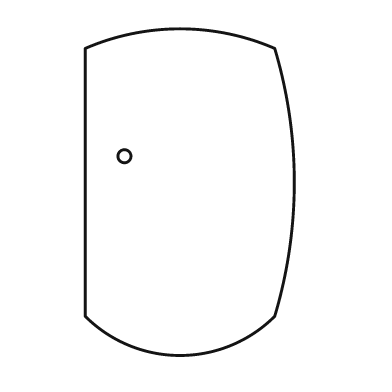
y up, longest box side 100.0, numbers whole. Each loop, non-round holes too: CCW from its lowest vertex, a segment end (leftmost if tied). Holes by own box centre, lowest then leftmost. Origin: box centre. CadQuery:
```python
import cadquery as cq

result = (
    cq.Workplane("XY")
    .moveTo(-32.0, -38.0)
    .threePointArc((-3.0, -50.0), (26.0, -38.0))
    .threePointArc((32.0, 3.0), (26.0, 44.0))
    .threePointArc((-3.0, 50.0), (-32.0, 44.0))
    .close()
    .moveTo(-20.0, 11.0)
    .circle(2.0)
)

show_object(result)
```